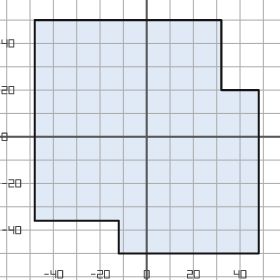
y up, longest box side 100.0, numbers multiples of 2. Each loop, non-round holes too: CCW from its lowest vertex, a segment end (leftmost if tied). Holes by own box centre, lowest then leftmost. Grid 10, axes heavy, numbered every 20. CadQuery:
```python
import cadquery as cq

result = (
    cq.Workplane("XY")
    .moveTo(-12.0, -50.0)
    .lineTo(48.0, -50.0)
    .lineTo(48.0, 20.0)
    .lineTo(32.0, 20.0)
    .lineTo(32.0, 50.0)
    .lineTo(-48.0, 50.0)
    .lineTo(-48.0, -36.0)
    .lineTo(-12.0, -36.0)
    .close()
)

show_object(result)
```